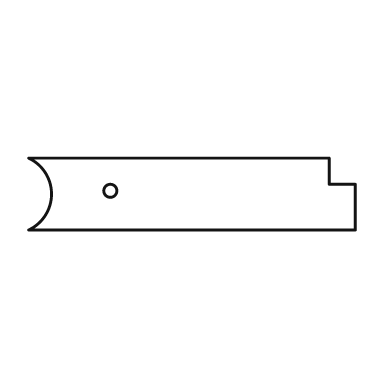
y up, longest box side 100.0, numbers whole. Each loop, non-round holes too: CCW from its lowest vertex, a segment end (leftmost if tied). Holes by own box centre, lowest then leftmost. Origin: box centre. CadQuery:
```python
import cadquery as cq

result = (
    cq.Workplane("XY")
    .moveTo(-50.0, -11.0)
    .lineTo(50.0, -11.0)
    .lineTo(50.0, 3.0)
    .lineTo(42.0, 3.0)
    .lineTo(42.0, 11.0)
    .lineTo(-50.0, 11.0)
    .threePointArc((-43.0, 0.0), (-50.0, -11.0))
    .close()
    .moveTo(-25.0, 1.0)
    .circle(2.0)
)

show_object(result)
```